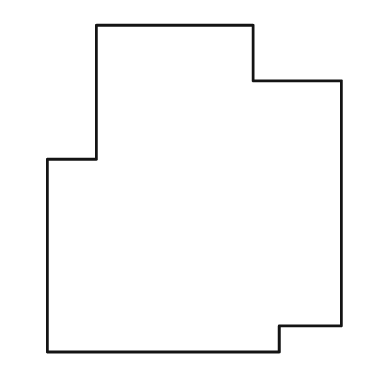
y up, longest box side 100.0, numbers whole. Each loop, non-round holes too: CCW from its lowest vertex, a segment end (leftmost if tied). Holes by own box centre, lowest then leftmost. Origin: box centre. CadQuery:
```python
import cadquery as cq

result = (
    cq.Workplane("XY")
    .moveTo(-45.0, -50.0)
    .lineTo(26.0, -50.0)
    .lineTo(26.0, -42.0)
    .lineTo(45.0, -42.0)
    .lineTo(45.0, 33.0)
    .lineTo(18.0, 33.0)
    .lineTo(18.0, 50.0)
    .lineTo(-30.0, 50.0)
    .lineTo(-30.0, 9.0)
    .lineTo(-45.0, 9.0)
    .close()
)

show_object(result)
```